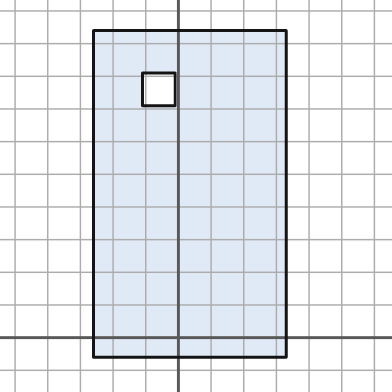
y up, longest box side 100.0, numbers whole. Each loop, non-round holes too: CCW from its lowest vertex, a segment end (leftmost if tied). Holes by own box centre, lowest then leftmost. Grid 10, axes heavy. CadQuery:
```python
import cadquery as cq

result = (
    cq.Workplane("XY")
    .moveTo(-26.0, -6.0)
    .lineTo(33.0, -6.0)
    .lineTo(33.0, 94.0)
    .lineTo(-26.0, 94.0)
    .close()
    .moveTo(-11.0, 71.0)
    .lineTo(-1.0, 71.0)
    .lineTo(-1.0, 81.0)
    .lineTo(-11.0, 81.0)
    .close()
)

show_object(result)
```